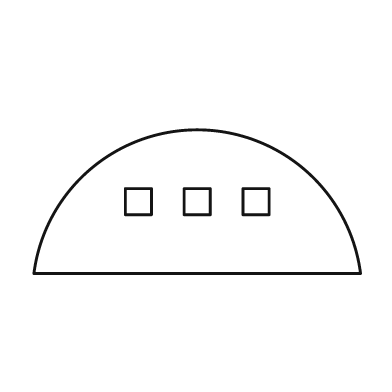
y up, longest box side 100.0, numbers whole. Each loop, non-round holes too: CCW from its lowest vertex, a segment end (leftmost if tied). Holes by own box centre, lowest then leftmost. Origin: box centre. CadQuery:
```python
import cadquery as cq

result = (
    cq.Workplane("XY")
    .moveTo(-50.0, -22.0)
    .lineTo(50.0, -22.0)
    .threePointArc((0.0, 22.0), (-50.0, -22.0))
    .close()
    .moveTo(-22.0, -4.0)
    .lineTo(-14.0, -4.0)
    .lineTo(-14.0, 4.0)
    .lineTo(-22.0, 4.0)
    .close()
    .moveTo(-4.0, -4.0)
    .lineTo(4.0, -4.0)
    .lineTo(4.0, 4.0)
    .lineTo(-4.0, 4.0)
    .close()
    .moveTo(14.0, -4.0)
    .lineTo(22.0, -4.0)
    .lineTo(22.0, 4.0)
    .lineTo(14.0, 4.0)
    .close()
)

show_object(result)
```